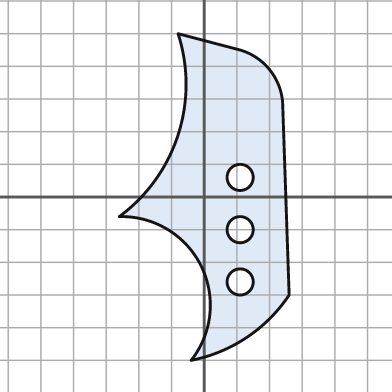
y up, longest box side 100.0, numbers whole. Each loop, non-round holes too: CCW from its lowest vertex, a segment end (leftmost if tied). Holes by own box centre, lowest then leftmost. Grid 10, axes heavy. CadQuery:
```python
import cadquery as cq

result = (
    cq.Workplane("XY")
    .moveTo(-4.0, -50.0)
    .threePointArc((13.0, -43.0), (26.0, -30.0))
    .lineTo(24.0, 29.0)
    .threePointArc((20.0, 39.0), (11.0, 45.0))
    .lineTo(-8.0, 50.0)
    .threePointArc((-8.0, 19.0), (-26.0, -6.0))
    .threePointArc((-1.0, -21.0), (-4.0, -50.0))
    .close()
    .moveTo(11.0, -26.0)
    .circle(4.0)
    .moveTo(11.0, -10.0)
    .circle(4.0)
    .moveTo(11.0, 6.0)
    .circle(4.0)
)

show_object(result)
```